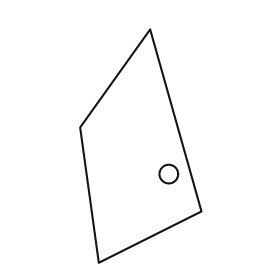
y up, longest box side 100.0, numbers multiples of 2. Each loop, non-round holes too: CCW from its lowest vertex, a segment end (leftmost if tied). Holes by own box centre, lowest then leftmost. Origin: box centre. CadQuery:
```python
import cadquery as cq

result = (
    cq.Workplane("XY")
    .moveTo(-18.0, -50.0)
    .lineTo(26.0, -28.0)
    .lineTo(4.0, 50.0)
    .lineTo(-26.0, 8.0)
    .close()
    .moveTo(12.0, -12.0)
    .circle(4.0)
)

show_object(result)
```